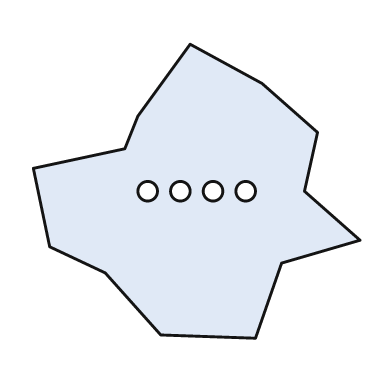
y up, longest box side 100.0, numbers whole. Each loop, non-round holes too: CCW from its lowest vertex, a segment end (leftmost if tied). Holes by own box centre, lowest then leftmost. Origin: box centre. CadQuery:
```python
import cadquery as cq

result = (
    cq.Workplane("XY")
    .moveTo(18.0, -45.0)
    .lineTo(26.0, -22.0)
    .lineTo(50.0, -15.0)
    .lineTo(33.0, 0.0)
    .lineTo(37.0, 18.0)
    .lineTo(20.0, 33.0)
    .lineTo(-2.0, 45.0)
    .lineTo(-18.0, 23.0)
    .lineTo(-22.0, 13.0)
    .lineTo(-50.0, 7.0)
    .lineTo(-45.0, -17.0)
    .lineTo(-28.0, -25.0)
    .lineTo(-11.0, -44.0)
    .close()
    .moveTo(-15.0, 0.0)
    .circle(3.0)
    .moveTo(-5.0, 0.0)
    .circle(3.0)
    .moveTo(5.0, 0.0)
    .circle(3.0)
    .moveTo(15.0, 0.0)
    .circle(3.0)
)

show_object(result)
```